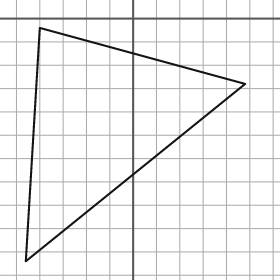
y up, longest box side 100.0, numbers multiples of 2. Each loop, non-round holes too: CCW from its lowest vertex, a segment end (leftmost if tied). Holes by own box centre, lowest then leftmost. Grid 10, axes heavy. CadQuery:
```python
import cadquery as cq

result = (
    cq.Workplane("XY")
    .moveTo(-46.0, -104.0)
    .lineTo(48.0, -28.0)
    .lineTo(-40.0, -4.0)
    .close()
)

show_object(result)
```